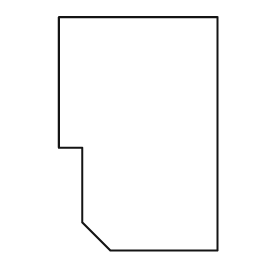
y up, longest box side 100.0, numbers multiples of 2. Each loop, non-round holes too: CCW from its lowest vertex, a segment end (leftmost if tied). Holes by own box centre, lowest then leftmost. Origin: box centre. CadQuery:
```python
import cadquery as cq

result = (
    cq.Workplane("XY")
    .moveTo(-12.0, -50.0)
    .lineTo(34.0, -50.0)
    .lineTo(34.0, 50.0)
    .lineTo(-34.0, 50.0)
    .lineTo(-34.0, -6.0)
    .lineTo(-24.0, -6.0)
    .lineTo(-24.0, -38.0)
    .close()
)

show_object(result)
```